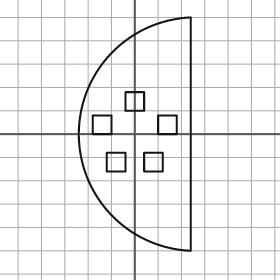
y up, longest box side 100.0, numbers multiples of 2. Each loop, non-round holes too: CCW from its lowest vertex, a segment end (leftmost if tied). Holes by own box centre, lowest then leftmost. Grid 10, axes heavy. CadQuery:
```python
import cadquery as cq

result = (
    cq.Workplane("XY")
    .moveTo(24.0, -50.0)
    .lineTo(24.0, 50.0)
    .threePointArc((-24.0, 0.0), (24.0, -50.0))
    .close()
    .moveTo(-12.0, -16.0)
    .lineTo(-4.0, -16.0)
    .lineTo(-4.0, -8.0)
    .lineTo(-12.0, -8.0)
    .close()
    .moveTo(4.0, -16.0)
    .lineTo(12.0, -16.0)
    .lineTo(12.0, -8.0)
    .lineTo(4.0, -8.0)
    .close()
    .moveTo(-18.0, 0.0)
    .lineTo(-10.0, 0.0)
    .lineTo(-10.0, 8.0)
    .lineTo(-18.0, 8.0)
    .close()
    .moveTo(10.0, 0.0)
    .lineTo(18.0, 0.0)
    .lineTo(18.0, 8.0)
    .lineTo(10.0, 8.0)
    .close()
    .moveTo(-4.0, 10.0)
    .lineTo(4.0, 10.0)
    .lineTo(4.0, 18.0)
    .lineTo(-4.0, 18.0)
    .close()
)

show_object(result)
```